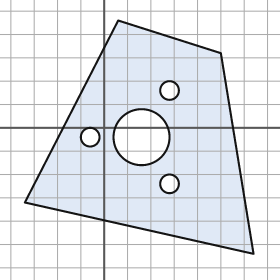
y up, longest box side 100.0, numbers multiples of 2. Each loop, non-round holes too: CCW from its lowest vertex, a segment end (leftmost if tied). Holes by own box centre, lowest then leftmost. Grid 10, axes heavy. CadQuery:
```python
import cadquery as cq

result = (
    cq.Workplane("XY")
    .moveTo(64.0, -54.0)
    .lineTo(50.0, 32.0)
    .lineTo(6.0, 46.0)
    .lineTo(-34.0, -32.0)
    .close()
    .moveTo(28.0, -24.0)
    .circle(4.0)
    .moveTo(-6.0, -4.0)
    .circle(4.0)
    .moveTo(16.0, -4.0)
    .circle(12.0)
    .moveTo(28.0, 16.0)
    .circle(4.0)
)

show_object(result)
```